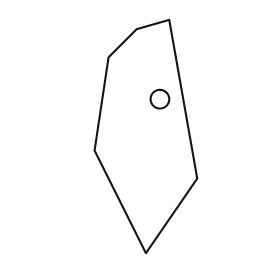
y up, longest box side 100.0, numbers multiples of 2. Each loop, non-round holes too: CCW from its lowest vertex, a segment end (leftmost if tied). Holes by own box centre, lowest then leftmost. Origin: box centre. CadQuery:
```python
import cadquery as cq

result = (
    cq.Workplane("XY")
    .moveTo(0.0, -50.0)
    .lineTo(22.0, -18.0)
    .lineTo(10.0, 50.0)
    .lineTo(-4.0, 46.0)
    .lineTo(-16.0, 34.0)
    .lineTo(-22.0, -6.0)
    .close()
    .moveTo(6.0, 16.0)
    .circle(4.0)
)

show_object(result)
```